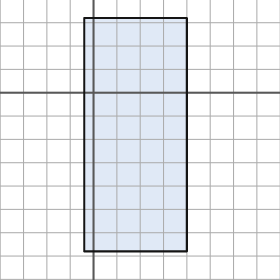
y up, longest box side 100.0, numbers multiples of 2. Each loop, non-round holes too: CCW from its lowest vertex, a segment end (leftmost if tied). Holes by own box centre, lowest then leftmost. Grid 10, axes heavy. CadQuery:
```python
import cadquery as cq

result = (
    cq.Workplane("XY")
    .moveTo(-4.0, -68.0)
    .lineTo(40.0, -68.0)
    .lineTo(40.0, 32.0)
    .lineTo(-4.0, 32.0)
    .close()
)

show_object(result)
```